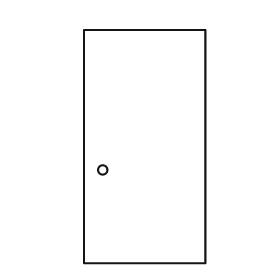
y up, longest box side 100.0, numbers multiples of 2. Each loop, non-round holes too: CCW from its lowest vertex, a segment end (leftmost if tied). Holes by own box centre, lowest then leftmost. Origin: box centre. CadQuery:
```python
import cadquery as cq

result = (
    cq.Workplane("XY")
    .moveTo(-26.0, -50.0)
    .lineTo(26.0, -50.0)
    .lineTo(26.0, 50.0)
    .lineTo(-26.0, 50.0)
    .close()
    .moveTo(-18.0, -10.0)
    .circle(2.0)
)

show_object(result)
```